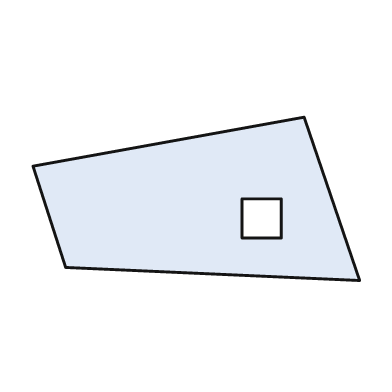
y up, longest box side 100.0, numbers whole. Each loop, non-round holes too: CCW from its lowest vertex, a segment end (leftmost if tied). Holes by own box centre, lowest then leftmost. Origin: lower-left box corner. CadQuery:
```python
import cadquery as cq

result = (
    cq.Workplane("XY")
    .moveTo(100.0, 0.0)
    .lineTo(83.0, 50.0)
    .lineTo(0.0, 35.0)
    .lineTo(10.0, 4.0)
    .close()
    .moveTo(64.0, 13.0)
    .lineTo(76.0, 13.0)
    .lineTo(76.0, 25.0)
    .lineTo(64.0, 25.0)
    .close()
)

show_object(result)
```